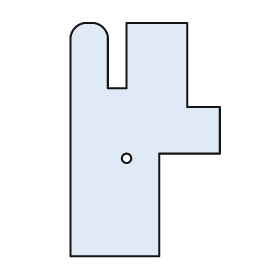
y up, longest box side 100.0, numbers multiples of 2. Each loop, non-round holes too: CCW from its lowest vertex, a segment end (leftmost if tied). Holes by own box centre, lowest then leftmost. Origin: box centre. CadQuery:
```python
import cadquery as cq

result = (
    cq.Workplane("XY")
    .moveTo(-32.0, -50.0)
    .lineTo(6.0, -50.0)
    .lineTo(6.0, -6.0)
    .lineTo(32.0, -6.0)
    .lineTo(32.0, 14.0)
    .lineTo(18.0, 14.0)
    .lineTo(18.0, 50.0)
    .lineTo(-8.0, 50.0)
    .lineTo(-8.0, 22.0)
    .lineTo(-16.0, 22.0)
    .lineTo(-16.0, 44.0)
    .threePointArc((-18.0, 48.0), (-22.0, 50.0))
    .lineTo(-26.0, 50.0)
    .threePointArc((-30.0, 48.0), (-32.0, 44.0))
    .close()
    .moveTo(-8.0, -8.0)
    .circle(2.0)
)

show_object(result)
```